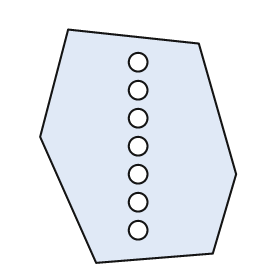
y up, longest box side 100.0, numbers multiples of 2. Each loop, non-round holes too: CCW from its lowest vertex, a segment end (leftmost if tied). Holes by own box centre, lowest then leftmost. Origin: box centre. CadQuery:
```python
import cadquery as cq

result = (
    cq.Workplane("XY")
    .moveTo(-18.0, -50.0)
    .lineTo(32.0, -46.0)
    .lineTo(42.0, -12.0)
    .lineTo(26.0, 44.0)
    .lineTo(-30.0, 50.0)
    .lineTo(-42.0, 4.0)
    .close()
    .moveTo(0.0, -36.0)
    .circle(4.0)
    .moveTo(0.0, -24.0)
    .circle(4.0)
    .moveTo(0.0, -12.0)
    .circle(4.0)
    .moveTo(0.0, 0.0)
    .circle(4.0)
    .moveTo(0.0, 12.0)
    .circle(4.0)
    .moveTo(0.0, 24.0)
    .circle(4.0)
    .moveTo(0.0, 36.0)
    .circle(4.0)
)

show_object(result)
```